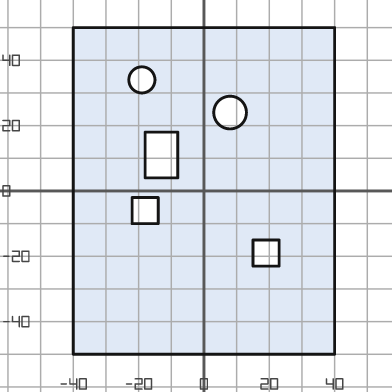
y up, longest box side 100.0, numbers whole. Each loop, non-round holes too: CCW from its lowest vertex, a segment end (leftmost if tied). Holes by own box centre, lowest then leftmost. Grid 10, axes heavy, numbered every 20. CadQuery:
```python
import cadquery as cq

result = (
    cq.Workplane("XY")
    .moveTo(-40.0, -50.0)
    .lineTo(40.0, -50.0)
    .lineTo(40.0, 50.0)
    .lineTo(-40.0, 50.0)
    .close()
    .moveTo(15.0, -23.0)
    .lineTo(23.0, -23.0)
    .lineTo(23.0, -15.0)
    .lineTo(15.0, -15.0)
    .close()
    .moveTo(-22.0, -10.0)
    .lineTo(-14.0, -10.0)
    .lineTo(-14.0, -2.0)
    .lineTo(-22.0, -2.0)
    .close()
    .moveTo(-18.0, 4.0)
    .lineTo(-8.0, 4.0)
    .lineTo(-8.0, 18.0)
    .lineTo(-18.0, 18.0)
    .close()
    .moveTo(8.0, 24.0)
    .circle(5.0)
    .moveTo(-19.0, 34.0)
    .circle(4.0)
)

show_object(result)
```